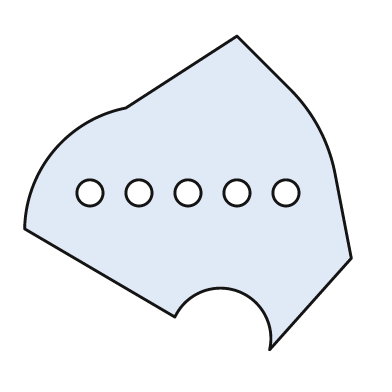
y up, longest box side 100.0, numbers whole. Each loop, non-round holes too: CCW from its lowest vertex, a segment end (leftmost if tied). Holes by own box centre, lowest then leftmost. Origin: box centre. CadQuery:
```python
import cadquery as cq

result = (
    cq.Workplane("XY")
    .moveTo(25.0, -48.0)
    .lineTo(50.0, -20.0)
    .lineTo(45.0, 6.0)
    .threePointArc((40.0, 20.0), (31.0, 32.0))
    .lineTo(15.0, 48.0)
    .lineTo(-19.0, 26.0)
    .threePointArc((-41.0, 13.0), (-50.0, -11.0))
    .lineTo(-4.0, -38.0)
    .threePointArc((15.0, -30.0), (25.0, -48.0))
    .close()
    .moveTo(-30.0, 0.0)
    .circle(4.0)
    .moveTo(-15.0, 0.0)
    .circle(4.0)
    .moveTo(0.0, 0.0)
    .circle(4.0)
    .moveTo(15.0, 0.0)
    .circle(4.0)
    .moveTo(30.0, 0.0)
    .circle(4.0)
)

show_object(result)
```